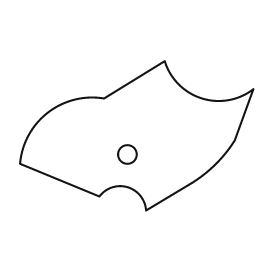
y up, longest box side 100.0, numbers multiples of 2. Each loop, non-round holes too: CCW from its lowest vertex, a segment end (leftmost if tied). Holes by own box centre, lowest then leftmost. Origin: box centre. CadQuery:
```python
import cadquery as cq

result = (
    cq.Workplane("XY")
    .moveTo(4.0, -32.0)
    .lineTo(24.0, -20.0)
    .threePointArc((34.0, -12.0), (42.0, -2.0))
    .lineTo(50.0, 20.0)
    .threePointArc((28.0, 16.0), (12.0, 32.0))
    .lineTo(-14.0, 16.0)
    .threePointArc((-38.0, 10.0), (-50.0, -12.0))
    .lineTo(-16.0, -26.0)
    .threePointArc((-4.0, -22.0), (4.0, -32.0))
    .close()
    .moveTo(-4.0, -8.0)
    .circle(4.0)
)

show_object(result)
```